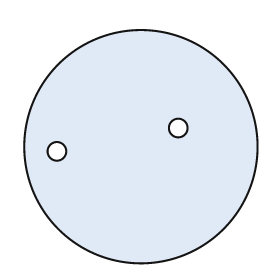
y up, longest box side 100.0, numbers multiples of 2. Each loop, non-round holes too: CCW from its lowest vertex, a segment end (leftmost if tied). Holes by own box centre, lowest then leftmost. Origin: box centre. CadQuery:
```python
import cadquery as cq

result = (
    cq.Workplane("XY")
    .moveTo(0.0, 0.0)
    .circle(50.0)
    .moveTo(-36.0, -2.0)
    .circle(4.0)
    .moveTo(16.0, 8.0)
    .circle(4.0)
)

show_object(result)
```